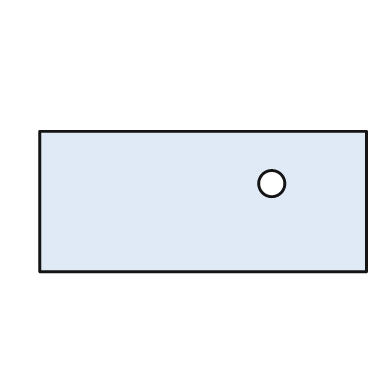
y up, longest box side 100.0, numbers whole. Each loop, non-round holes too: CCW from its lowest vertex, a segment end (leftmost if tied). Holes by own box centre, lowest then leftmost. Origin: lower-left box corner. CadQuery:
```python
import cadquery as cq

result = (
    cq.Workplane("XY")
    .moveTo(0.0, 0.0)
    .lineTo(100.0, 0.0)
    .lineTo(100.0, 43.0)
    .lineTo(0.0, 43.0)
    .close()
    .moveTo(71.0, 27.0)
    .circle(4.0)
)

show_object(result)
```